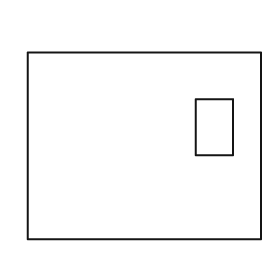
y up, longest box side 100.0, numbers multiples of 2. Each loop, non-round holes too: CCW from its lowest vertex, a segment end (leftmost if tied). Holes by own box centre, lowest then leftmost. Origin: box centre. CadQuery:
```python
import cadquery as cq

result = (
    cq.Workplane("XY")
    .moveTo(-50.0, -40.0)
    .lineTo(50.0, -40.0)
    .lineTo(50.0, 40.0)
    .lineTo(-50.0, 40.0)
    .close()
    .moveTo(22.0, -4.0)
    .lineTo(38.0, -4.0)
    .lineTo(38.0, 20.0)
    .lineTo(22.0, 20.0)
    .close()
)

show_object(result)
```